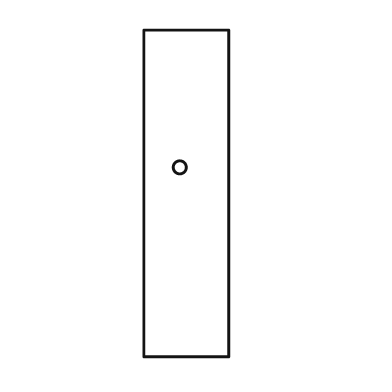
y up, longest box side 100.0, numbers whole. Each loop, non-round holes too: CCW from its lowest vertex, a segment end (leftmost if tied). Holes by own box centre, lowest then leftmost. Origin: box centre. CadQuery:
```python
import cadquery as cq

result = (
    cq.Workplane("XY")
    .moveTo(-13.0, -50.0)
    .lineTo(13.0, -50.0)
    .lineTo(13.0, 50.0)
    .lineTo(-13.0, 50.0)
    .close()
    .moveTo(-2.0, 8.0)
    .circle(2.0)
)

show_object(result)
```